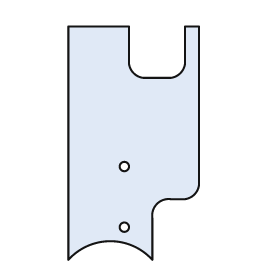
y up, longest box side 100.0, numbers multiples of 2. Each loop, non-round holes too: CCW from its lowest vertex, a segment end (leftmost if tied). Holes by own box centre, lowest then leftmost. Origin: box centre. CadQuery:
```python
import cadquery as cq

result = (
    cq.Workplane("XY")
    .moveTo(-28.0, -50.0)
    .threePointArc((-10.0, -42.0), (8.0, -50.0))
    .lineTo(8.0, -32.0)
    .threePointArc((10.0, -26.0), (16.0, -24.0))
    .lineTo(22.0, -24.0)
    .threePointArc((26.0, -22.0), (28.0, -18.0))
    .lineTo(28.0, 50.0)
    .lineTo(22.0, 50.0)
    .lineTo(22.0, 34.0)
    .threePointArc((20.0, 30.0), (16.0, 28.0))
    .lineTo(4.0, 28.0)
    .threePointArc((0.0, 30.0), (-2.0, 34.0))
    .lineTo(-2.0, 50.0)
    .lineTo(-28.0, 50.0)
    .close()
    .moveTo(-4.0, -36.0)
    .circle(2.0)
    .moveTo(-4.0, -10.0)
    .circle(2.0)
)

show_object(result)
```